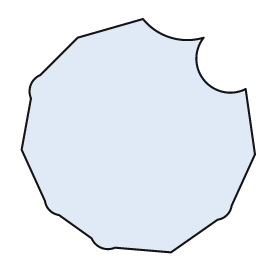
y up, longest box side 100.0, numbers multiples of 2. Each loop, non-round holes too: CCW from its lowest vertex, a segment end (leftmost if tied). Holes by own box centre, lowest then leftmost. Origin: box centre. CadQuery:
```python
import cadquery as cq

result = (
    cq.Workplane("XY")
    .moveTo(14.0, -50.0)
    .lineTo(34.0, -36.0)
    .threePointArc((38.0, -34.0), (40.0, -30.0))
    .lineTo(50.0, -8.0)
    .lineTo(46.0, 20.0)
    .threePointArc((28.0, 24.0), (28.0, 42.0))
    .threePointArc((14.0, 42.0), (2.0, 50.0))
    .lineTo(-26.0, 42.0)
    .lineTo(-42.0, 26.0)
    .threePointArc((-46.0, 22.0), (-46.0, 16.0))
    .lineTo(-50.0, -6.0)
    .lineTo(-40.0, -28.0)
    .threePointArc((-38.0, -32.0), (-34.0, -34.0))
    .lineTo(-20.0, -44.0)
    .threePointArc((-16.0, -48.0), (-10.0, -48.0))
    .close()
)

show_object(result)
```